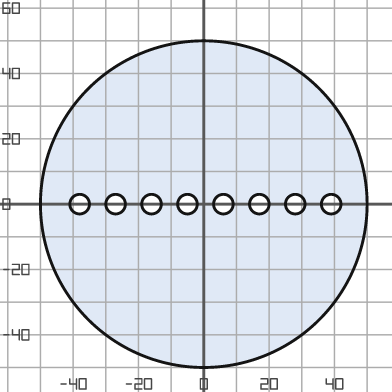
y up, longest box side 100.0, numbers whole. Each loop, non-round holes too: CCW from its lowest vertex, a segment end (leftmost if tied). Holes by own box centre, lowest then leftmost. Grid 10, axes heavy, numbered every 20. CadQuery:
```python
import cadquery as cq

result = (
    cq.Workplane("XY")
    .moveTo(0.0, 0.0)
    .circle(50.0)
    .moveTo(-38.0, 0.0)
    .circle(3.0)
    .moveTo(-27.0, 0.0)
    .circle(3.0)
    .moveTo(-16.0, 0.0)
    .circle(3.0)
    .moveTo(-5.0, 0.0)
    .circle(3.0)
    .moveTo(6.0, 0.0)
    .circle(3.0)
    .moveTo(17.0, 0.0)
    .circle(3.0)
    .moveTo(28.0, 0.0)
    .circle(3.0)
    .moveTo(39.0, 0.0)
    .circle(3.0)
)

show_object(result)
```